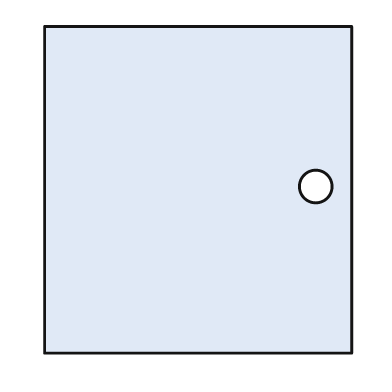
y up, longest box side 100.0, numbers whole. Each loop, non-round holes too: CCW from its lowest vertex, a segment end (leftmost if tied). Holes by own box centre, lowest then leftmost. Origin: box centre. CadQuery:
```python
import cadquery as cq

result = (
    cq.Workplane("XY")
    .moveTo(-47.0, -50.0)
    .lineTo(47.0, -50.0)
    .lineTo(47.0, 50.0)
    .lineTo(-47.0, 50.0)
    .close()
    .moveTo(36.0, 1.0)
    .circle(5.0)
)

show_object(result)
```